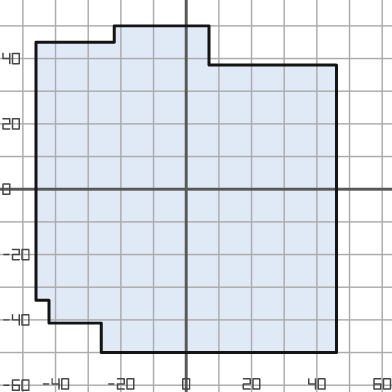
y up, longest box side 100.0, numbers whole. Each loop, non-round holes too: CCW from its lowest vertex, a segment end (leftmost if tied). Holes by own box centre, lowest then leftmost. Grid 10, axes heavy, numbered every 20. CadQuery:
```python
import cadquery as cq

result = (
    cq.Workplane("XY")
    .moveTo(-26.0, -50.0)
    .lineTo(46.0, -50.0)
    .lineTo(46.0, 38.0)
    .lineTo(7.0, 38.0)
    .lineTo(7.0, 50.0)
    .lineTo(-22.0, 50.0)
    .lineTo(-22.0, 45.0)
    .lineTo(-46.0, 45.0)
    .lineTo(-46.0, -34.0)
    .lineTo(-42.0, -34.0)
    .lineTo(-42.0, -41.0)
    .lineTo(-26.0, -41.0)
    .close()
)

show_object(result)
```